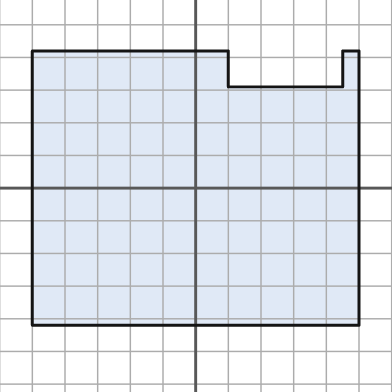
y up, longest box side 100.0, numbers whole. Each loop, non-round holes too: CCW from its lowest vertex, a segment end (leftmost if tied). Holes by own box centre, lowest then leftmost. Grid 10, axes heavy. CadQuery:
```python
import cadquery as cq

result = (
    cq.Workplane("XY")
    .moveTo(-50.0, -42.0)
    .lineTo(50.0, -42.0)
    .lineTo(50.0, 42.0)
    .lineTo(45.0, 42.0)
    .lineTo(45.0, 31.0)
    .lineTo(10.0, 31.0)
    .lineTo(10.0, 42.0)
    .lineTo(-50.0, 42.0)
    .close()
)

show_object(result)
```